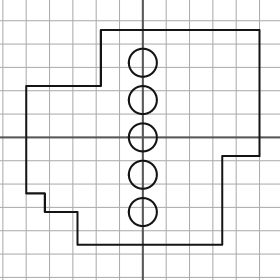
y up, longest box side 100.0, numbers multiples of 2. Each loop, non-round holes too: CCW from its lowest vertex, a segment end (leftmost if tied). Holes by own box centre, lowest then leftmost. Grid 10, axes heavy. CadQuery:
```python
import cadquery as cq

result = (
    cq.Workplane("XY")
    .moveTo(-28.0, -46.0)
    .lineTo(34.0, -46.0)
    .lineTo(34.0, -8.0)
    .lineTo(50.0, -8.0)
    .lineTo(50.0, 46.0)
    .lineTo(-18.0, 46.0)
    .lineTo(-18.0, 22.0)
    .lineTo(-50.0, 22.0)
    .lineTo(-50.0, -24.0)
    .lineTo(-42.0, -24.0)
    .lineTo(-42.0, -32.0)
    .lineTo(-28.0, -32.0)
    .close()
    .moveTo(0.0, -32.0)
    .circle(6.0)
    .moveTo(0.0, -16.0)
    .circle(6.0)
    .moveTo(0.0, 0.0)
    .circle(6.0)
    .moveTo(0.0, 16.0)
    .circle(6.0)
    .moveTo(0.0, 32.0)
    .circle(6.0)
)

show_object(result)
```